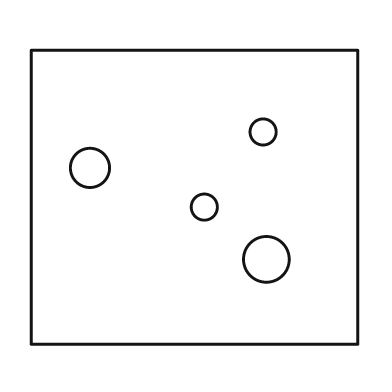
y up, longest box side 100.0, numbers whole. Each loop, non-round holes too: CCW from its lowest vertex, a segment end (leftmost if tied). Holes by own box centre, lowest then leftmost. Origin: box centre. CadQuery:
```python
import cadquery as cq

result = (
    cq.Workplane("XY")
    .moveTo(-50.0, -45.0)
    .lineTo(50.0, -45.0)
    .lineTo(50.0, 45.0)
    .lineTo(-50.0, 45.0)
    .close()
    .moveTo(22.0, -19.0)
    .circle(7.0)
    .moveTo(3.0, -3.0)
    .circle(4.0)
    .moveTo(-32.0, 9.0)
    .circle(6.0)
    .moveTo(21.0, 20.0)
    .circle(4.0)
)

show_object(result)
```